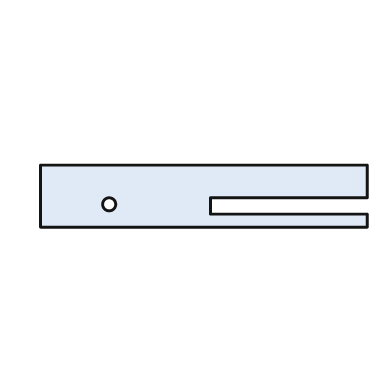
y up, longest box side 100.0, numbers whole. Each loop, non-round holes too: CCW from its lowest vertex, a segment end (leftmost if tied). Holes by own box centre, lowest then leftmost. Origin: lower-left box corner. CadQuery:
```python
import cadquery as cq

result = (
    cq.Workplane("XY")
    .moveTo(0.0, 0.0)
    .lineTo(100.0, 0.0)
    .lineTo(100.0, 4.0)
    .lineTo(52.0, 4.0)
    .lineTo(52.0, 9.0)
    .lineTo(100.0, 9.0)
    .lineTo(100.0, 19.0)
    .lineTo(0.0, 19.0)
    .close()
    .moveTo(21.0, 7.0)
    .circle(2.0)
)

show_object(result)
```